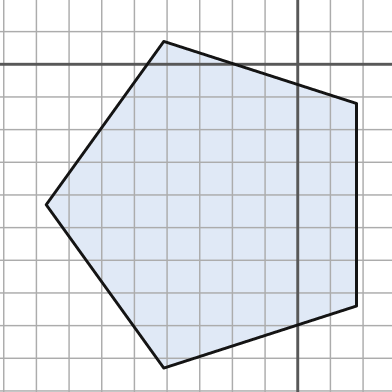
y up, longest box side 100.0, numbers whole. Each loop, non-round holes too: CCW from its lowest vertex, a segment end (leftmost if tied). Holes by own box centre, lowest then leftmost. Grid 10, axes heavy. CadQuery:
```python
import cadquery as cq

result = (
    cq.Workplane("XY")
    .moveTo(-41.0, -93.0)
    .lineTo(18.0, -74.0)
    .lineTo(18.0, -12.0)
    .lineTo(-41.0, 7.0)
    .lineTo(-77.0, -43.0)
    .close()
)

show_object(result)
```